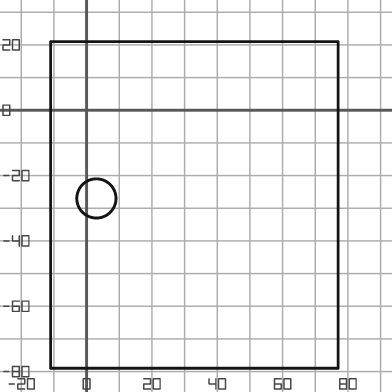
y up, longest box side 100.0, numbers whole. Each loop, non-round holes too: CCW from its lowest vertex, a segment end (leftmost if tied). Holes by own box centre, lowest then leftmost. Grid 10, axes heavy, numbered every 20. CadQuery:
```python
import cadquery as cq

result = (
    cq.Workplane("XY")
    .moveTo(-11.0, -79.0)
    .lineTo(77.0, -79.0)
    .lineTo(77.0, 21.0)
    .lineTo(-11.0, 21.0)
    .close()
    .moveTo(3.0, -27.0)
    .circle(6.0)
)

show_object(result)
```